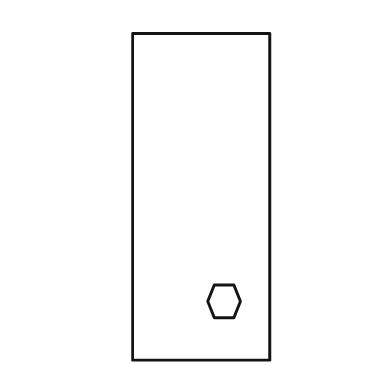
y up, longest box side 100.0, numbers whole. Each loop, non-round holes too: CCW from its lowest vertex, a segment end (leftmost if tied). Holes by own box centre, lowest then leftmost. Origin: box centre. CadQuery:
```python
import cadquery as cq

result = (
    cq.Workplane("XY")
    .moveTo(-21.0, -50.0)
    .lineTo(21.0, -50.0)
    .lineTo(21.0, 50.0)
    .lineTo(-21.0, 50.0)
    .close()
    .moveTo(4.0, -37.0)
    .lineTo(10.0, -37.0)
    .lineTo(12.0, -32.0)
    .lineTo(10.0, -27.0)
    .lineTo(4.0, -27.0)
    .lineTo(2.0, -32.0)
    .close()
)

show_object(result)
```